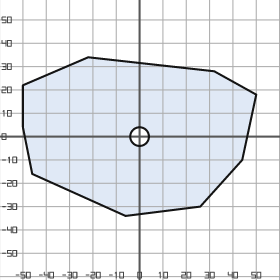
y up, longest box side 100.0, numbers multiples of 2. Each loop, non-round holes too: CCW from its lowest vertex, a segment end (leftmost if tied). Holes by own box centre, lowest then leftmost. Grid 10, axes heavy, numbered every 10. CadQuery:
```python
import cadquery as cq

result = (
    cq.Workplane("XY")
    .moveTo(-6.0, -34.0)
    .lineTo(26.0, -30.0)
    .lineTo(44.0, -10.0)
    .lineTo(50.0, 18.0)
    .lineTo(32.0, 28.0)
    .lineTo(-22.0, 34.0)
    .lineTo(-50.0, 22.0)
    .lineTo(-50.0, 4.0)
    .lineTo(-46.0, -16.0)
    .close()
    .moveTo(0.0, 0.0)
    .circle(4.0)
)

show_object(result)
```